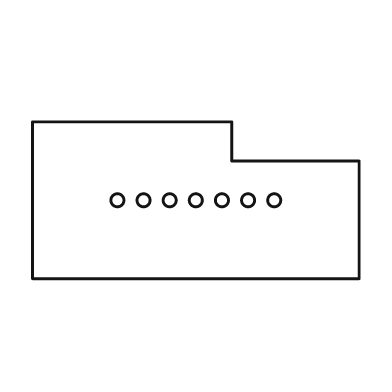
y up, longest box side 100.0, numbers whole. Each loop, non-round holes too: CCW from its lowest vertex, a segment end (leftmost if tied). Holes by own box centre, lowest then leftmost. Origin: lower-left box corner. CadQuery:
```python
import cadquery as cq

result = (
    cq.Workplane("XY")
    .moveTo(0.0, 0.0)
    .lineTo(100.0, 0.0)
    .lineTo(100.0, 36.0)
    .lineTo(61.0, 36.0)
    .lineTo(61.0, 48.0)
    .lineTo(0.0, 48.0)
    .close()
    .moveTo(26.0, 24.0)
    .circle(2.0)
    .moveTo(34.0, 24.0)
    .circle(2.0)
    .moveTo(42.0, 24.0)
    .circle(2.0)
    .moveTo(50.0, 24.0)
    .circle(2.0)
    .moveTo(58.0, 24.0)
    .circle(2.0)
    .moveTo(66.0, 24.0)
    .circle(2.0)
    .moveTo(74.0, 24.0)
    .circle(2.0)
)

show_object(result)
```